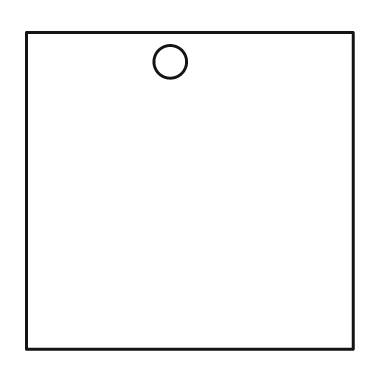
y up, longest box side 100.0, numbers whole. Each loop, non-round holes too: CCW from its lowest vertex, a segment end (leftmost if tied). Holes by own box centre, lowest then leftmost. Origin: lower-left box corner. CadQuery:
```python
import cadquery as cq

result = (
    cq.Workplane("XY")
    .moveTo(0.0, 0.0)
    .lineTo(100.0, 0.0)
    .lineTo(100.0, 97.0)
    .lineTo(0.0, 97.0)
    .close()
    .moveTo(44.0, 88.0)
    .circle(5.0)
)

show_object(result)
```